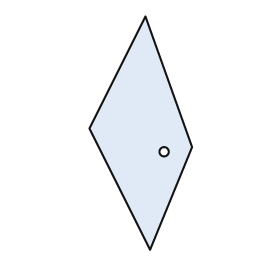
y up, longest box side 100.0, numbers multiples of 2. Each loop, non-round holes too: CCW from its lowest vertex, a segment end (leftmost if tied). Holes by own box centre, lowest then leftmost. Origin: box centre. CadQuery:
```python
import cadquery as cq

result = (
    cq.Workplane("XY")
    .moveTo(4.0, -50.0)
    .lineTo(22.0, -6.0)
    .lineTo(2.0, 50.0)
    .lineTo(-22.0, 2.0)
    .close()
    .moveTo(10.0, -8.0)
    .circle(2.0)
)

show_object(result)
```